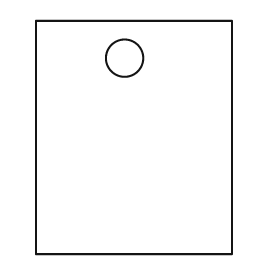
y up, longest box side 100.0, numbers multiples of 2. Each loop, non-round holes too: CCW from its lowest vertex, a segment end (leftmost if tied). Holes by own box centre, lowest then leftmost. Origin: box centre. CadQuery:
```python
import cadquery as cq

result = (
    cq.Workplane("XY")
    .moveTo(-42.0, -50.0)
    .lineTo(42.0, -50.0)
    .lineTo(42.0, 50.0)
    .lineTo(-42.0, 50.0)
    .close()
    .moveTo(-4.0, 34.0)
    .circle(8.0)
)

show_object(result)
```